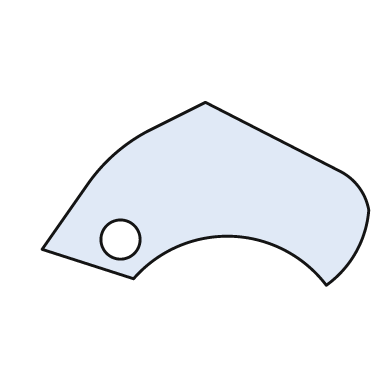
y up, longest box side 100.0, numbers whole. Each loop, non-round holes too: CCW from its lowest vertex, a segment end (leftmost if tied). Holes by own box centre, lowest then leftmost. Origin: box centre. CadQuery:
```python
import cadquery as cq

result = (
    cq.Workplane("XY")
    .moveTo(37.0, -28.0)
    .threePointArc((46.0, -18.0), (50.0, -5.0))
    .threePointArc((47.0, 2.0), (41.0, 7.0))
    .lineTo(0.0, 28.0)
    .lineTo(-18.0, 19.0)
    .threePointArc((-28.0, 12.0), (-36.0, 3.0))
    .lineTo(-50.0, -17.0)
    .lineTo(-22.0, -26.0)
    .threePointArc((8.0, -13.0), (37.0, -28.0))
    .close()
    .moveTo(-26.0, -14.0)
    .circle(6.0)
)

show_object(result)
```